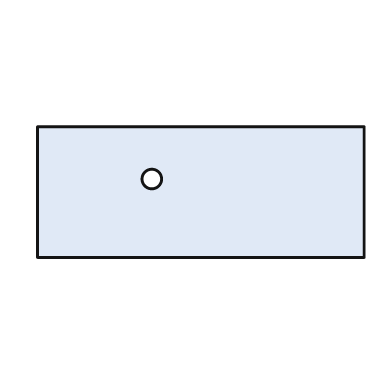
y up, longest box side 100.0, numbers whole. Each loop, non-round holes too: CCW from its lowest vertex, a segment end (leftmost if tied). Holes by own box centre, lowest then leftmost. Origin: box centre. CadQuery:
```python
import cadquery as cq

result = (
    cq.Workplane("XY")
    .moveTo(-50.0, -20.0)
    .lineTo(50.0, -20.0)
    .lineTo(50.0, 20.0)
    .lineTo(-50.0, 20.0)
    .close()
    .moveTo(-15.0, 4.0)
    .circle(3.0)
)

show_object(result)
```